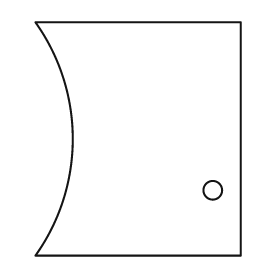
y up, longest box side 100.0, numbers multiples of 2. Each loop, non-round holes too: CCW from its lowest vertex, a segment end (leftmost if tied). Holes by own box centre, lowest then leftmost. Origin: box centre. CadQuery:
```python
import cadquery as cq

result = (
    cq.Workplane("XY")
    .moveTo(-44.0, -50.0)
    .lineTo(44.0, -50.0)
    .lineTo(44.0, 50.0)
    .lineTo(-44.0, 50.0)
    .threePointArc((-28.0, 0.0), (-44.0, -50.0))
    .close()
    .moveTo(32.0, -22.0)
    .circle(4.0)
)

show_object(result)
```